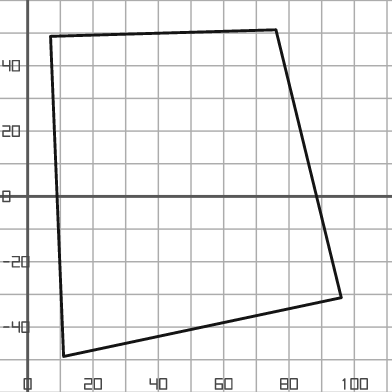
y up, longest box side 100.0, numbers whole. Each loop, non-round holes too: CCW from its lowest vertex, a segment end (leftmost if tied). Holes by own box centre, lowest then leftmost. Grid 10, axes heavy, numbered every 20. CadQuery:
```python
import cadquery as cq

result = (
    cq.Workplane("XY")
    .moveTo(11.0, -49.0)
    .lineTo(96.0, -31.0)
    .lineTo(76.0, 51.0)
    .lineTo(7.0, 49.0)
    .close()
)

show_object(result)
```